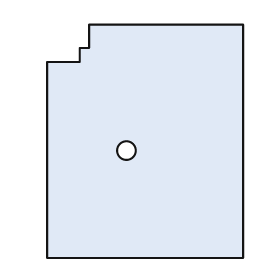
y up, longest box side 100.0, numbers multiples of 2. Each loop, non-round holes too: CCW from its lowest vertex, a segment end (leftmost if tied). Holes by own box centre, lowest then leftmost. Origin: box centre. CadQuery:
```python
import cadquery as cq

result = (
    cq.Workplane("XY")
    .moveTo(-42.0, -50.0)
    .lineTo(42.0, -50.0)
    .lineTo(42.0, 50.0)
    .lineTo(-24.0, 50.0)
    .lineTo(-24.0, 40.0)
    .lineTo(-28.0, 40.0)
    .lineTo(-28.0, 34.0)
    .lineTo(-42.0, 34.0)
    .close()
    .moveTo(-8.0, -4.0)
    .circle(4.0)
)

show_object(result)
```